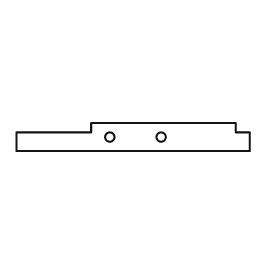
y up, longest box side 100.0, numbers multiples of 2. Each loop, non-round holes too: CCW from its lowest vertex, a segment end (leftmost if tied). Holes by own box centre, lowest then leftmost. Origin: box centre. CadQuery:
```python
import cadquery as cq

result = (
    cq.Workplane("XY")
    .moveTo(-50.0, -6.0)
    .lineTo(50.0, -6.0)
    .lineTo(50.0, 2.0)
    .lineTo(44.0, 2.0)
    .lineTo(44.0, 6.0)
    .lineTo(-18.0, 6.0)
    .lineTo(-18.0, 2.0)
    .lineTo(-50.0, 2.0)
    .close()
    .moveTo(-10.0, 0.0)
    .circle(2.0)
    .moveTo(12.0, 0.0)
    .circle(2.0)
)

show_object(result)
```